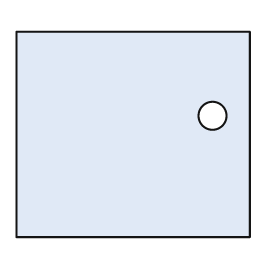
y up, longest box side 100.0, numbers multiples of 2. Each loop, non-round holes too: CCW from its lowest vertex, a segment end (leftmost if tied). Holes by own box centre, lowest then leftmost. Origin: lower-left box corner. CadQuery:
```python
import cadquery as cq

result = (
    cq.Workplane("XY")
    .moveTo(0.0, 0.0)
    .lineTo(100.0, 0.0)
    .lineTo(100.0, 88.0)
    .lineTo(0.0, 88.0)
    .close()
    .moveTo(84.0, 52.0)
    .circle(6.0)
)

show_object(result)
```